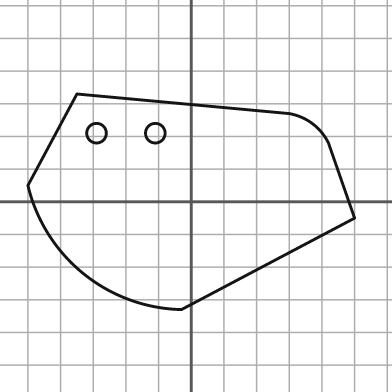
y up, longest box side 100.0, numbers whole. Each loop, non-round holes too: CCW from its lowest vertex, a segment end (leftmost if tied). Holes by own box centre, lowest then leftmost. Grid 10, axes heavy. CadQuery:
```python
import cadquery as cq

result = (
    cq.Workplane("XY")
    .moveTo(-3.0, -33.0)
    .lineTo(50.0, -5.0)
    .lineTo(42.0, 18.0)
    .threePointArc((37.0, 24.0), (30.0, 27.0))
    .lineTo(-35.0, 33.0)
    .lineTo(-50.0, 5.0)
    .threePointArc((-33.0, -22.0), (-3.0, -33.0))
    .close()
    .moveTo(-29.0, 21.0)
    .circle(3.0)
    .moveTo(-11.0, 21.0)
    .circle(3.0)
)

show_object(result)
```